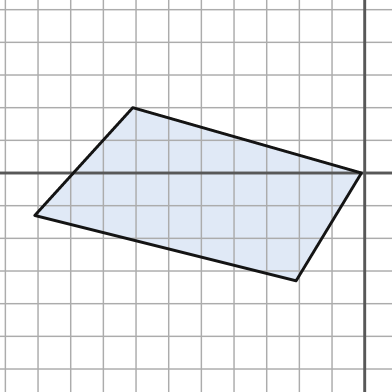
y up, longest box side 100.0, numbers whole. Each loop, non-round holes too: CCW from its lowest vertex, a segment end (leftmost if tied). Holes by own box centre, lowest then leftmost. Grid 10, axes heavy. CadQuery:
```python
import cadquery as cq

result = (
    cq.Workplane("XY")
    .moveTo(-21.0, -33.0)
    .lineTo(-1.0, 0.0)
    .lineTo(-71.0, 20.0)
    .lineTo(-101.0, -13.0)
    .close()
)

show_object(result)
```